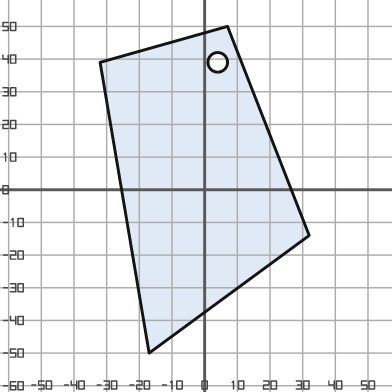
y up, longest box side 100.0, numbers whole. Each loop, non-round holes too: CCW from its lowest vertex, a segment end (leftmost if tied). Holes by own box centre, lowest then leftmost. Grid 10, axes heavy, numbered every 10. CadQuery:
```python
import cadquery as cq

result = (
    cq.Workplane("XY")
    .moveTo(-17.0, -50.0)
    .lineTo(32.0, -14.0)
    .lineTo(7.0, 50.0)
    .lineTo(-32.0, 39.0)
    .close()
    .moveTo(4.0, 39.0)
    .circle(3.0)
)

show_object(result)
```